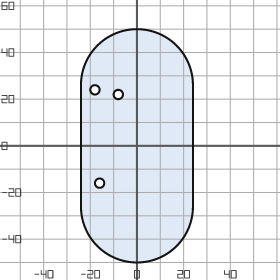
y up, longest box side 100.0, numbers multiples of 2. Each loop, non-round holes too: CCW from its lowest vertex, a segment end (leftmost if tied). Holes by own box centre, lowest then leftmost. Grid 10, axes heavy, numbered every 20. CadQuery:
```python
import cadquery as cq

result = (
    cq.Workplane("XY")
    .moveTo(-24.0, -26.0)
    .threePointArc((0.0, -50.0), (24.0, -26.0))
    .lineTo(24.0, 26.0)
    .threePointArc((0.0, 50.0), (-24.0, 26.0))
    .close()
    .moveTo(-16.0, -16.0)
    .circle(2.0)
    .moveTo(-8.0, 22.0)
    .circle(2.0)
    .moveTo(-18.0, 24.0)
    .circle(2.0)
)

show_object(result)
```